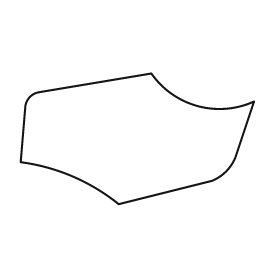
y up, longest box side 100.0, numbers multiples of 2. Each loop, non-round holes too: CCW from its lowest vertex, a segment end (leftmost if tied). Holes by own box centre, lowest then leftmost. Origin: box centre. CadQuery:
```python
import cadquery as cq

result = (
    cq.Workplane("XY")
    .moveTo(-8.0, -28.0)
    .lineTo(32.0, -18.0)
    .threePointArc((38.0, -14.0), (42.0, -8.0))
    .lineTo(50.0, 16.0)
    .threePointArc((26.0, 14.0), (6.0, 28.0))
    .lineTo(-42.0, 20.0)
    .threePointArc((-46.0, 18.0), (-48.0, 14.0))
    .lineTo(-50.0, -10.0)
    .threePointArc((-28.0, -16.0), (-8.0, -28.0))
    .close()
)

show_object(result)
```